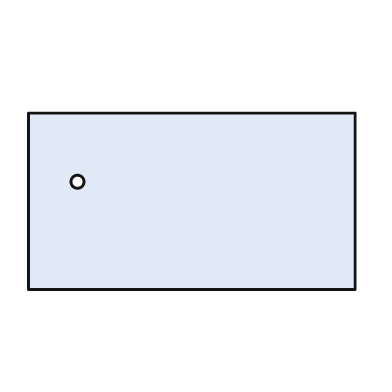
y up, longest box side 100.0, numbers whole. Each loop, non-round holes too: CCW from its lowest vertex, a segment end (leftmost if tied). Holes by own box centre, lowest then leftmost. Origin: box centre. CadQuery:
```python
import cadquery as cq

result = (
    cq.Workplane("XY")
    .moveTo(-50.0, -27.0)
    .lineTo(50.0, -27.0)
    .lineTo(50.0, 27.0)
    .lineTo(-50.0, 27.0)
    .close()
    .moveTo(-35.0, 6.0)
    .circle(2.0)
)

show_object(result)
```